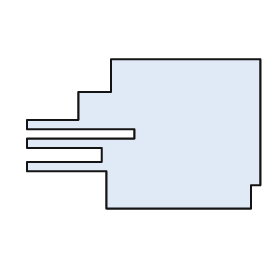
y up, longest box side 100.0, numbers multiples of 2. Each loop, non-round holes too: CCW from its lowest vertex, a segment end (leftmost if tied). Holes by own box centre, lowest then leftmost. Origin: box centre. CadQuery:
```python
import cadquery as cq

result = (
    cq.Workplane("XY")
    .moveTo(-16.0, -32.0)
    .lineTo(46.0, -32.0)
    .lineTo(46.0, -22.0)
    .lineTo(50.0, -22.0)
    .lineTo(50.0, 32.0)
    .lineTo(-14.0, 32.0)
    .lineTo(-14.0, 18.0)
    .lineTo(-28.0, 18.0)
    .lineTo(-28.0, 6.0)
    .lineTo(-50.0, 6.0)
    .lineTo(-50.0, 2.0)
    .lineTo(-4.0, 2.0)
    .lineTo(-4.0, -2.0)
    .lineTo(-50.0, -2.0)
    .lineTo(-50.0, -6.0)
    .lineTo(-18.0, -6.0)
    .lineTo(-18.0, -12.0)
    .lineTo(-50.0, -12.0)
    .lineTo(-50.0, -16.0)
    .lineTo(-16.0, -16.0)
    .close()
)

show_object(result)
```